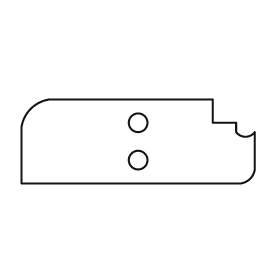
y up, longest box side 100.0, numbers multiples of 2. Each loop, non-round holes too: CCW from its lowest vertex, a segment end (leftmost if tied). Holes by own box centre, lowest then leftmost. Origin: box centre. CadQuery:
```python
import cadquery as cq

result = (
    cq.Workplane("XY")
    .moveTo(-50.0, -18.0)
    .lineTo(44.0, -18.0)
    .threePointArc((48.0, -16.0), (50.0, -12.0))
    .lineTo(50.0, 4.0)
    .threePointArc((46.0, 2.0), (42.0, 4.0))
    .lineTo(42.0, 8.0)
    .lineTo(32.0, 8.0)
    .lineTo(32.0, 18.0)
    .lineTo(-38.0, 18.0)
    .threePointArc((-46.0, 14.0), (-50.0, 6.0))
    .close()
    .moveTo(0.0, -8.0)
    .circle(4.0)
    .moveTo(0.0, 8.0)
    .circle(4.0)
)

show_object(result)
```